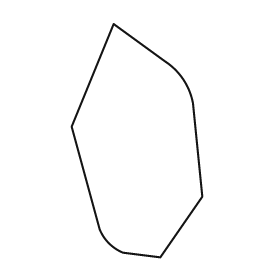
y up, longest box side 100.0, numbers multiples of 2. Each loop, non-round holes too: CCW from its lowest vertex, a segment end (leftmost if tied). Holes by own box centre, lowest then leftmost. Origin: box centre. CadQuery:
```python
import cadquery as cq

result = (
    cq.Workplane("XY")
    .moveTo(10.0, -50.0)
    .lineTo(28.0, -24.0)
    .lineTo(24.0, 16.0)
    .threePointArc((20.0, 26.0), (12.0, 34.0))
    .lineTo(-10.0, 50.0)
    .lineTo(-28.0, 6.0)
    .lineTo(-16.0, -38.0)
    .threePointArc((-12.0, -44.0), (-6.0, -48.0))
    .close()
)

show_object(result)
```